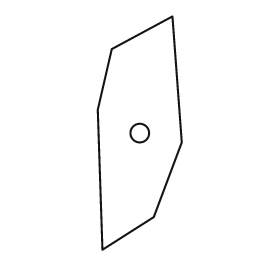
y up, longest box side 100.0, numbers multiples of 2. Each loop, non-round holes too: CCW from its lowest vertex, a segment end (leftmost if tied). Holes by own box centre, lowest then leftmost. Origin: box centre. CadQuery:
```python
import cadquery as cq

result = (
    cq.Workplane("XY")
    .moveTo(-16.0, -50.0)
    .lineTo(6.0, -36.0)
    .lineTo(18.0, -4.0)
    .lineTo(14.0, 50.0)
    .lineTo(-12.0, 36.0)
    .lineTo(-18.0, 10.0)
    .close()
    .moveTo(0.0, 0.0)
    .circle(4.0)
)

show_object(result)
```